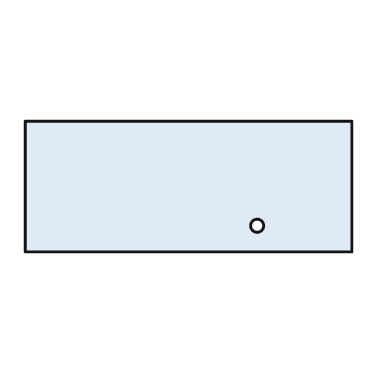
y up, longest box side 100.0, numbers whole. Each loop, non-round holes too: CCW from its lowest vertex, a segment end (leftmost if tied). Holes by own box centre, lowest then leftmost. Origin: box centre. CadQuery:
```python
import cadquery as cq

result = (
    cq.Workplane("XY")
    .moveTo(-50.0, -20.0)
    .lineTo(50.0, -20.0)
    .lineTo(50.0, 20.0)
    .lineTo(-50.0, 20.0)
    .close()
    .moveTo(21.0, -12.0)
    .circle(2.0)
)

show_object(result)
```